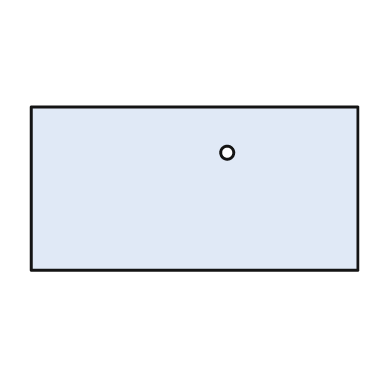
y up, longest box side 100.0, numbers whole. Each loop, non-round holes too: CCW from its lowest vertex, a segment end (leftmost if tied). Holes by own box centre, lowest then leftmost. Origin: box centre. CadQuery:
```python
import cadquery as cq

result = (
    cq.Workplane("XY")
    .moveTo(-50.0, -25.0)
    .lineTo(50.0, -25.0)
    .lineTo(50.0, 25.0)
    .lineTo(-50.0, 25.0)
    .close()
    .moveTo(10.0, 11.0)
    .circle(2.0)
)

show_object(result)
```